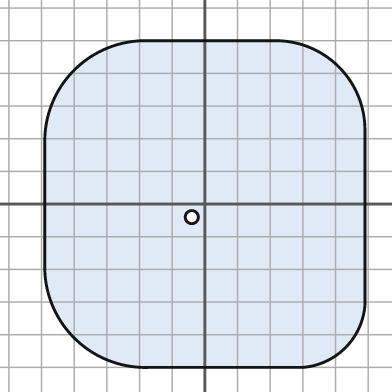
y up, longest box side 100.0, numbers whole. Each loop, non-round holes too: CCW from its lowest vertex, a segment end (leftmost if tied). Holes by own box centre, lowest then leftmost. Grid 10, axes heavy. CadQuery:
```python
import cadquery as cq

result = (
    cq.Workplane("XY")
    .moveTo(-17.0, -50.0)
    .lineTo(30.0, -50.0)
    .threePointArc((43.0, -44.0), (49.0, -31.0))
    .lineTo(49.0, 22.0)
    .threePointArc((41.0, 42.0), (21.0, 50.0))
    .lineTo(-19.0, 50.0)
    .threePointArc((-40.0, 41.0), (-49.0, 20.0))
    .lineTo(-49.0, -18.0)
    .threePointArc((-40.0, -41.0), (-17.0, -50.0))
    .close()
    .moveTo(-4.0, -4.0)
    .circle(2.0)
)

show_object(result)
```